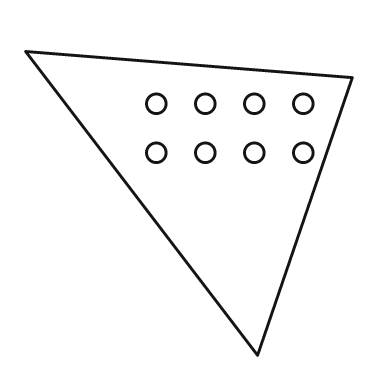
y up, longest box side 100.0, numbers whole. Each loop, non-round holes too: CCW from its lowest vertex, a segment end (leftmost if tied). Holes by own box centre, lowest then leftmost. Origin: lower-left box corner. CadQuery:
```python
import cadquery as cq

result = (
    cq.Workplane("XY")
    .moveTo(71.0, 0.0)
    .lineTo(100.0, 85.0)
    .lineTo(0.0, 93.0)
    .close()
    .moveTo(40.0, 62.0)
    .circle(3.0)
    .moveTo(55.0, 62.0)
    .circle(3.0)
    .moveTo(70.0, 62.0)
    .circle(3.0)
    .moveTo(85.0, 62.0)
    .circle(3.0)
    .moveTo(40.0, 77.0)
    .circle(3.0)
    .moveTo(55.0, 77.0)
    .circle(3.0)
    .moveTo(70.0, 77.0)
    .circle(3.0)
    .moveTo(85.0, 77.0)
    .circle(3.0)
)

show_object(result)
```